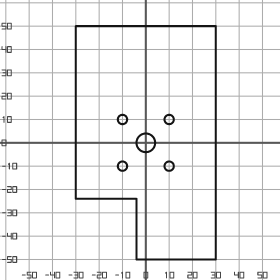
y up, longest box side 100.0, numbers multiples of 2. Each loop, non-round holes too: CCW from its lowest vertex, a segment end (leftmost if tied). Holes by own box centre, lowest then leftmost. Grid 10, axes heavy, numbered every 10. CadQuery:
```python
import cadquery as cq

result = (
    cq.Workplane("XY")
    .moveTo(-4.0, -50.0)
    .lineTo(30.0, -50.0)
    .lineTo(30.0, 50.0)
    .lineTo(-30.0, 50.0)
    .lineTo(-30.0, -24.0)
    .lineTo(-4.0, -24.0)
    .close()
    .moveTo(-10.0, -10.0)
    .circle(2.0)
    .moveTo(10.0, -10.0)
    .circle(2.0)
    .moveTo(0.0, 0.0)
    .circle(4.0)
    .moveTo(-10.0, 10.0)
    .circle(2.0)
    .moveTo(10.0, 10.0)
    .circle(2.0)
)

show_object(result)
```